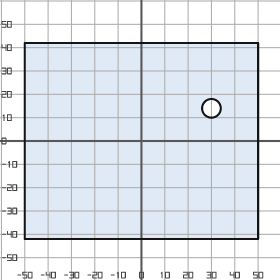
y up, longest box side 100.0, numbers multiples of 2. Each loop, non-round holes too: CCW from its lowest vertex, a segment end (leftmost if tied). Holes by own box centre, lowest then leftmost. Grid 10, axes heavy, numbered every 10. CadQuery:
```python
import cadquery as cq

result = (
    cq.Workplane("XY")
    .moveTo(-50.0, -42.0)
    .lineTo(50.0, -42.0)
    .lineTo(50.0, 42.0)
    .lineTo(-50.0, 42.0)
    .close()
    .moveTo(30.0, 14.0)
    .circle(4.0)
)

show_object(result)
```